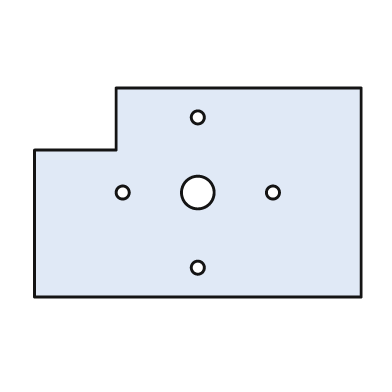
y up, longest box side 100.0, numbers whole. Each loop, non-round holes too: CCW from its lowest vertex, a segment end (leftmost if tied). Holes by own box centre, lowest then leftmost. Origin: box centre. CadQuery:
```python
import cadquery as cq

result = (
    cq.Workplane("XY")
    .moveTo(-50.0, -32.0)
    .lineTo(50.0, -32.0)
    .lineTo(50.0, 32.0)
    .lineTo(-25.0, 32.0)
    .lineTo(-25.0, 13.0)
    .lineTo(-50.0, 13.0)
    .close()
    .moveTo(0.0, -23.0)
    .circle(2.0)
    .moveTo(-23.0, 0.0)
    .circle(2.0)
    .moveTo(0.0, 0.0)
    .circle(5.0)
    .moveTo(23.0, 0.0)
    .circle(2.0)
    .moveTo(0.0, 23.0)
    .circle(2.0)
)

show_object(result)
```